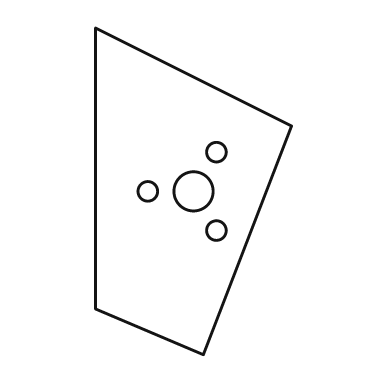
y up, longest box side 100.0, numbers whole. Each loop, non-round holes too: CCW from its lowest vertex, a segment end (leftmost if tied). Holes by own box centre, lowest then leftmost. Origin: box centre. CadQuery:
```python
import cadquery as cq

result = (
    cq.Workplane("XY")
    .moveTo(3.0, -50.0)
    .lineTo(30.0, 20.0)
    .lineTo(-30.0, 50.0)
    .lineTo(-30.0, -36.0)
    .close()
    .moveTo(7.0, -12.0)
    .circle(3.0)
    .moveTo(-14.0, 0.0)
    .circle(3.0)
    .moveTo(0.0, 0.0)
    .circle(6.0)
    .moveTo(7.0, 12.0)
    .circle(3.0)
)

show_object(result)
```